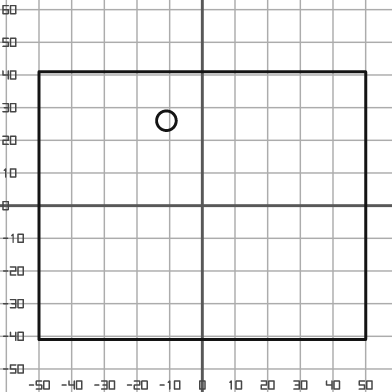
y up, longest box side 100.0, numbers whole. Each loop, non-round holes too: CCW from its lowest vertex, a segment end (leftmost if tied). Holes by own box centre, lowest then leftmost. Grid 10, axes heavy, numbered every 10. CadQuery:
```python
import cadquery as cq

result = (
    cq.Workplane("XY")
    .moveTo(-50.0, -41.0)
    .lineTo(50.0, -41.0)
    .lineTo(50.0, 41.0)
    .lineTo(-50.0, 41.0)
    .close()
    .moveTo(-11.0, 26.0)
    .circle(3.0)
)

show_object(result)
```